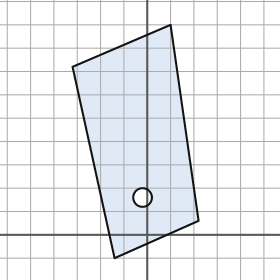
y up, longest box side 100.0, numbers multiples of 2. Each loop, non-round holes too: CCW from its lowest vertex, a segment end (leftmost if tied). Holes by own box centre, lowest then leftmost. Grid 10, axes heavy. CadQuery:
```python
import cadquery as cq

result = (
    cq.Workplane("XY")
    .moveTo(-14.0, -10.0)
    .lineTo(22.0, 6.0)
    .lineTo(10.0, 90.0)
    .lineTo(-32.0, 72.0)
    .close()
    .moveTo(-2.0, 16.0)
    .circle(4.0)
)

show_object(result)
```